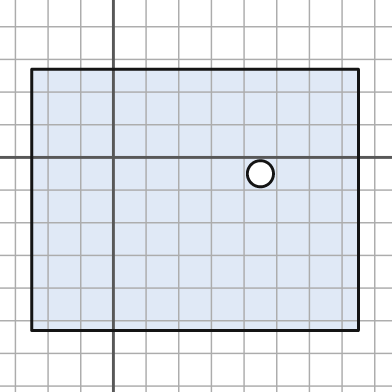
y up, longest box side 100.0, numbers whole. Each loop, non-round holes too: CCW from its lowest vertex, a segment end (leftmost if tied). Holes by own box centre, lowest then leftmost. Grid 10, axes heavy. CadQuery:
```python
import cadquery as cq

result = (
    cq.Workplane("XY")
    .moveTo(-25.0, -53.0)
    .lineTo(75.0, -53.0)
    .lineTo(75.0, 27.0)
    .lineTo(-25.0, 27.0)
    .close()
    .moveTo(45.0, -5.0)
    .circle(4.0)
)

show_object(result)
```